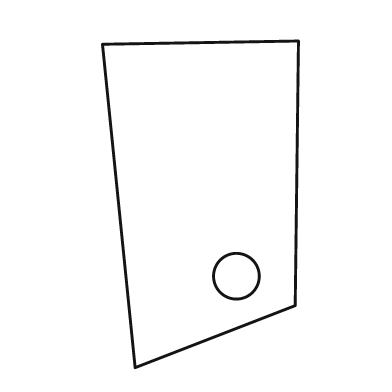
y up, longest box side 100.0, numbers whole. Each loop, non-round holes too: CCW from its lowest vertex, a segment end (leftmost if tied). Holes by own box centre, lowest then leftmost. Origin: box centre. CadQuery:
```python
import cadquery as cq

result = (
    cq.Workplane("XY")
    .moveTo(-20.0, -50.0)
    .lineTo(29.0, -31.0)
    .lineTo(30.0, 50.0)
    .lineTo(-30.0, 49.0)
    .close()
    .moveTo(11.0, -22.0)
    .circle(7.0)
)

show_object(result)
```